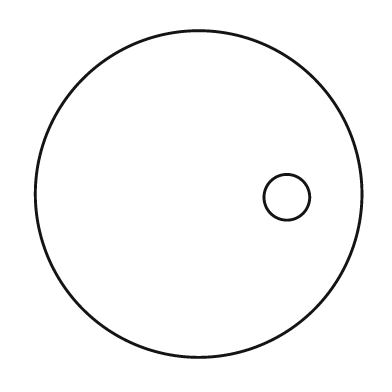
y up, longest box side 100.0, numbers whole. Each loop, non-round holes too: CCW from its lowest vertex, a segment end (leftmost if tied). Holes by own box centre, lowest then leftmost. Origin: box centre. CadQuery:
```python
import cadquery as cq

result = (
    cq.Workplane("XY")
    .moveTo(0.0, 0.0)
    .circle(50.0)
    .moveTo(27.0, -1.0)
    .circle(7.0)
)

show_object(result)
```